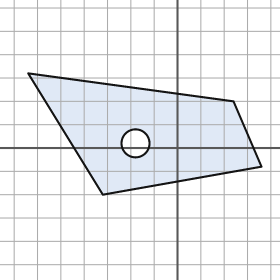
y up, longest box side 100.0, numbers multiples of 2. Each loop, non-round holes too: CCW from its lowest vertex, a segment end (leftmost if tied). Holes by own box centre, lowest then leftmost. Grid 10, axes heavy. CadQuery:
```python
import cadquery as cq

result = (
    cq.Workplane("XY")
    .moveTo(-32.0, -20.0)
    .lineTo(36.0, -8.0)
    .lineTo(24.0, 20.0)
    .lineTo(-64.0, 32.0)
    .close()
    .moveTo(-18.0, 2.0)
    .circle(6.0)
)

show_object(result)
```